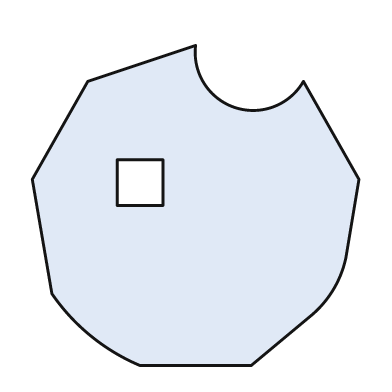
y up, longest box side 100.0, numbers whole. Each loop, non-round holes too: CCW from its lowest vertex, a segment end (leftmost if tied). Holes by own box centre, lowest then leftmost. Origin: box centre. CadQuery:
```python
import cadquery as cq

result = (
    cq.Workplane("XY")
    .moveTo(-17.0, -49.0)
    .lineTo(17.0, -49.0)
    .lineTo(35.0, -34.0)
    .threePointArc((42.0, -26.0), (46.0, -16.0))
    .lineTo(50.0, 8.0)
    .lineTo(33.0, 38.0)
    .threePointArc((12.0, 30.0), (0.0, 49.0))
    .lineTo(-33.0, 38.0)
    .lineTo(-50.0, 8.0)
    .lineTo(-44.0, -27.0)
    .threePointArc((-32.0, -40.0), (-17.0, -49.0))
    .close()
    .moveTo(-24.0, 0.0)
    .lineTo(-10.0, 0.0)
    .lineTo(-10.0, 14.0)
    .lineTo(-24.0, 14.0)
    .close()
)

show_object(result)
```